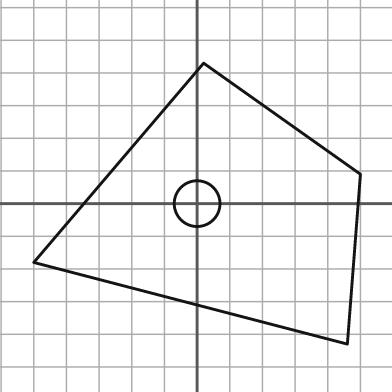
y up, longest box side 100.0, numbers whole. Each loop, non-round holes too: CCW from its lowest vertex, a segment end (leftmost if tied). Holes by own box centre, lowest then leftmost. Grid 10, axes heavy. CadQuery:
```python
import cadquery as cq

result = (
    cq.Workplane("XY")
    .moveTo(46.0, -43.0)
    .lineTo(50.0, 9.0)
    .lineTo(2.0, 43.0)
    .lineTo(-50.0, -18.0)
    .close()
    .moveTo(0.0, 0.0)
    .circle(7.0)
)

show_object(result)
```